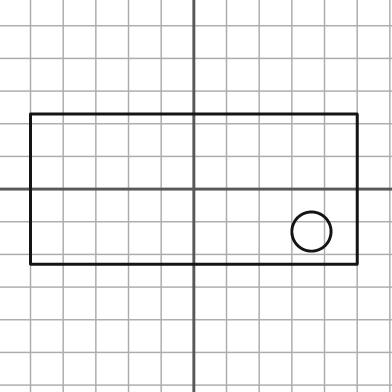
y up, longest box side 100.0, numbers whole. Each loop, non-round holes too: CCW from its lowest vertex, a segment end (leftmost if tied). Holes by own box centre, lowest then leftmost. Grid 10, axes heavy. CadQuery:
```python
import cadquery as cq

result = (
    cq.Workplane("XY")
    .moveTo(-50.0, -23.0)
    .lineTo(50.0, -23.0)
    .lineTo(50.0, 23.0)
    .lineTo(-50.0, 23.0)
    .close()
    .moveTo(36.0, -13.0)
    .circle(6.0)
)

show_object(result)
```